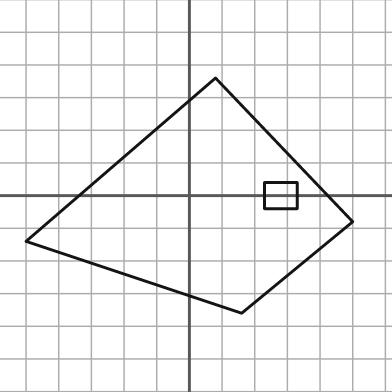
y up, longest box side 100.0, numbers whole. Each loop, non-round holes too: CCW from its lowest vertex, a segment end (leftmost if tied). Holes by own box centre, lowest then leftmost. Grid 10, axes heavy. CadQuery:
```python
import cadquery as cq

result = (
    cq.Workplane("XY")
    .moveTo(16.0, -36.0)
    .lineTo(50.0, -8.0)
    .lineTo(8.0, 36.0)
    .lineTo(-50.0, -14.0)
    .close()
    .moveTo(23.0, -4.0)
    .lineTo(33.0, -4.0)
    .lineTo(33.0, 4.0)
    .lineTo(23.0, 4.0)
    .close()
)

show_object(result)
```